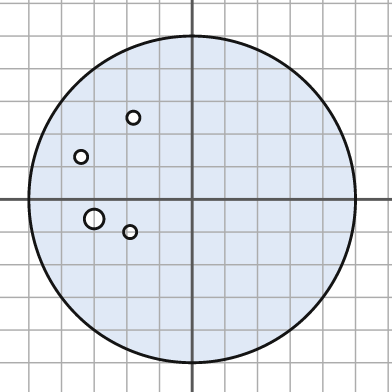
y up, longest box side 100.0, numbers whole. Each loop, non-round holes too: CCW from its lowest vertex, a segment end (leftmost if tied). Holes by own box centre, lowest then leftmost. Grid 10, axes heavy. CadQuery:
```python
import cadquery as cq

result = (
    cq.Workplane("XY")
    .moveTo(0.0, 0.0)
    .circle(50.0)
    .moveTo(-19.0, -10.0)
    .circle(2.0)
    .moveTo(-30.0, -6.0)
    .circle(3.0)
    .moveTo(-34.0, 13.0)
    .circle(2.0)
    .moveTo(-18.0, 25.0)
    .circle(2.0)
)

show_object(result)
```